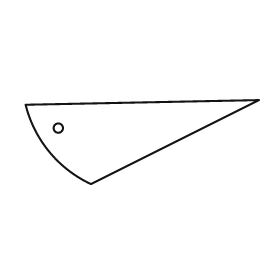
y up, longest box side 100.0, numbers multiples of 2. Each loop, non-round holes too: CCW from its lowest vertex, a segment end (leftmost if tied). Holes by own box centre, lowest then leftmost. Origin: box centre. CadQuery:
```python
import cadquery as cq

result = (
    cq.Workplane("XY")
    .moveTo(-22.0, -18.0)
    .lineTo(50.0, 18.0)
    .lineTo(-50.0, 16.0)
    .threePointArc((-40.0, -4.0), (-22.0, -18.0))
    .close()
    .moveTo(-36.0, 6.0)
    .circle(2.0)
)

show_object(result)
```